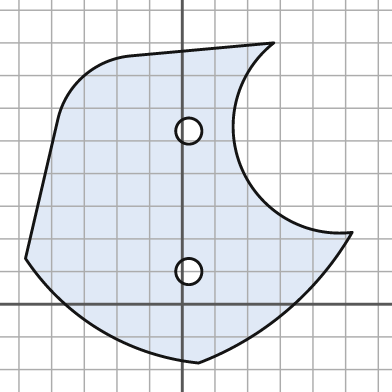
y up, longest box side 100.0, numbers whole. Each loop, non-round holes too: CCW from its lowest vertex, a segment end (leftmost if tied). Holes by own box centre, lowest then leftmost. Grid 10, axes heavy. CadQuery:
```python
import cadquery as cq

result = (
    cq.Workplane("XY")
    .moveTo(5.0, -18.0)
    .threePointArc((32.0, -2.0), (52.0, 22.0))
    .threePointArc((18.0, 42.0), (28.0, 80.0))
    .lineTo(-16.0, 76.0)
    .threePointArc((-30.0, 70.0), (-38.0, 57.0))
    .lineTo(-48.0, 14.0)
    .threePointArc((-25.0, -8.0), (5.0, -18.0))
    .close()
    .moveTo(2.0, 10.0)
    .circle(4.0)
    .moveTo(2.0, 53.0)
    .circle(4.0)
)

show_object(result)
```